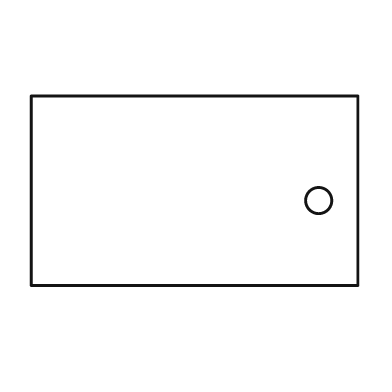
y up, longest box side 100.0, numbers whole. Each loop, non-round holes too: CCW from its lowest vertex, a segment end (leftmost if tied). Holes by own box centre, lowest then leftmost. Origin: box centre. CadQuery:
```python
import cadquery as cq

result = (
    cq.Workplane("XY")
    .moveTo(-50.0, -29.0)
    .lineTo(50.0, -29.0)
    .lineTo(50.0, 29.0)
    .lineTo(-50.0, 29.0)
    .close()
    .moveTo(38.0, -3.0)
    .circle(4.0)
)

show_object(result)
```